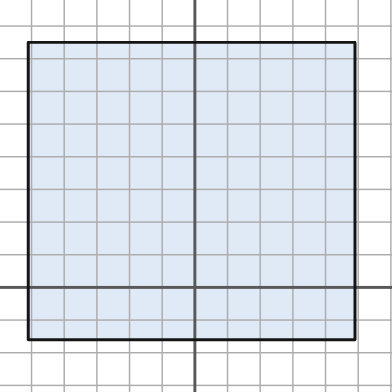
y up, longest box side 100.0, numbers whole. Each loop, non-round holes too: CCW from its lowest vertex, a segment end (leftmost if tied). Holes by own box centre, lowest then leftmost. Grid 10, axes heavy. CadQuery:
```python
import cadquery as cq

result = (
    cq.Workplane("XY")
    .moveTo(-51.0, -16.0)
    .lineTo(49.0, -16.0)
    .lineTo(49.0, 75.0)
    .lineTo(-51.0, 75.0)
    .close()
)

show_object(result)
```